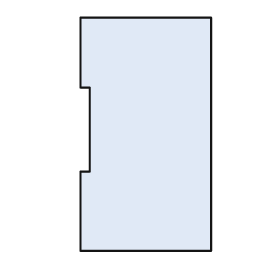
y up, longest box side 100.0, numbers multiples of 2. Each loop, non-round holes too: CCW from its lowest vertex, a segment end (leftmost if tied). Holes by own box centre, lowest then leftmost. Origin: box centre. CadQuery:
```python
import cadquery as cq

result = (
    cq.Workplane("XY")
    .moveTo(-28.0, -50.0)
    .lineTo(28.0, -50.0)
    .lineTo(28.0, 50.0)
    .lineTo(-28.0, 50.0)
    .lineTo(-28.0, 20.0)
    .lineTo(-24.0, 20.0)
    .lineTo(-24.0, -16.0)
    .lineTo(-28.0, -16.0)
    .close()
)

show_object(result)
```